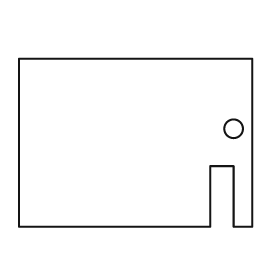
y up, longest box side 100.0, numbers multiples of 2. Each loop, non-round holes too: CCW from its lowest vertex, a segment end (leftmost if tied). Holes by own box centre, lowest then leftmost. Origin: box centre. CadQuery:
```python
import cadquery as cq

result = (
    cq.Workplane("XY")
    .moveTo(-50.0, -36.0)
    .lineTo(32.0, -36.0)
    .lineTo(32.0, -10.0)
    .lineTo(42.0, -10.0)
    .lineTo(42.0, -36.0)
    .lineTo(50.0, -36.0)
    .lineTo(50.0, 36.0)
    .lineTo(-50.0, 36.0)
    .close()
    .moveTo(42.0, 6.0)
    .circle(4.0)
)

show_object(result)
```